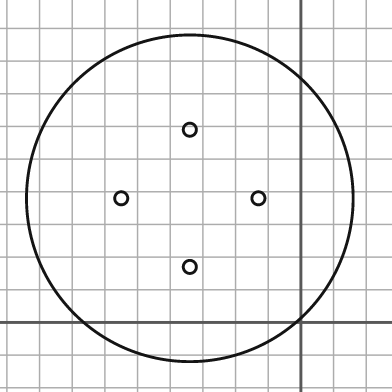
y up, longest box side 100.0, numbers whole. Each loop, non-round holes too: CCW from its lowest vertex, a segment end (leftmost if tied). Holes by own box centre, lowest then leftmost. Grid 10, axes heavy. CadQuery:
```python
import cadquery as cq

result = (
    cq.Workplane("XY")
    .moveTo(-34.0, 38.0)
    .circle(50.0)
    .moveTo(-34.0, 17.0)
    .circle(2.0)
    .moveTo(-55.0, 38.0)
    .circle(2.0)
    .moveTo(-13.0, 38.0)
    .circle(2.0)
    .moveTo(-34.0, 59.0)
    .circle(2.0)
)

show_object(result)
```